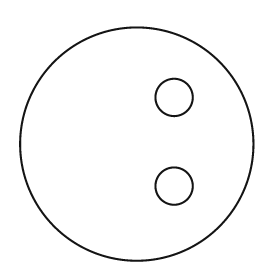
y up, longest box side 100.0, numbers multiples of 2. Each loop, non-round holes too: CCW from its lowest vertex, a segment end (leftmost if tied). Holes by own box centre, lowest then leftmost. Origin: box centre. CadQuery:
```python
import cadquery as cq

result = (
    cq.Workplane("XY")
    .moveTo(0.0, 0.0)
    .circle(50.0)
    .moveTo(16.0, -18.0)
    .circle(8.0)
    .moveTo(16.0, 20.0)
    .circle(8.0)
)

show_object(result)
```